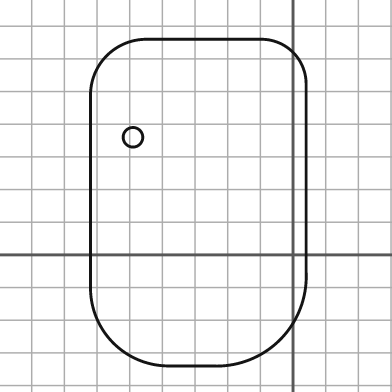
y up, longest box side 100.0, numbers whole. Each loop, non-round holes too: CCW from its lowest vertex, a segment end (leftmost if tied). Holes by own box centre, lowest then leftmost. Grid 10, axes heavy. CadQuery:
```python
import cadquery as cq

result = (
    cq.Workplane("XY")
    .moveTo(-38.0, -34.0)
    .lineTo(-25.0, -34.0)
    .threePointArc((-4.0, -26.0), (4.0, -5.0))
    .lineTo(4.0, 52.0)
    .threePointArc((0.0, 62.0), (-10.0, 66.0))
    .lineTo(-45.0, 66.0)
    .threePointArc((-57.0, 61.0), (-62.0, 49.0))
    .lineTo(-62.0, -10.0)
    .threePointArc((-55.0, -27.0), (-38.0, -34.0))
    .close()
    .moveTo(-49.0, 36.0)
    .circle(3.0)
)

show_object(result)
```